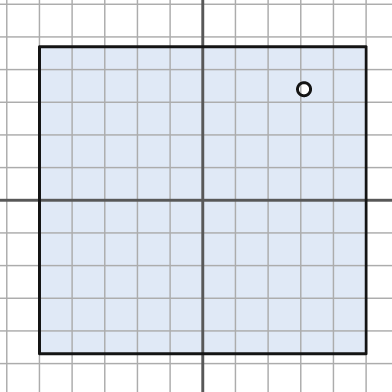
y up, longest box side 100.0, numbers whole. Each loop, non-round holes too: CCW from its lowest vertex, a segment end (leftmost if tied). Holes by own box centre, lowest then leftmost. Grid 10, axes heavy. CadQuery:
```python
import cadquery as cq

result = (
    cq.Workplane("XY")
    .moveTo(-50.0, -47.0)
    .lineTo(50.0, -47.0)
    .lineTo(50.0, 47.0)
    .lineTo(-50.0, 47.0)
    .close()
    .moveTo(31.0, 34.0)
    .circle(2.0)
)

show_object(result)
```